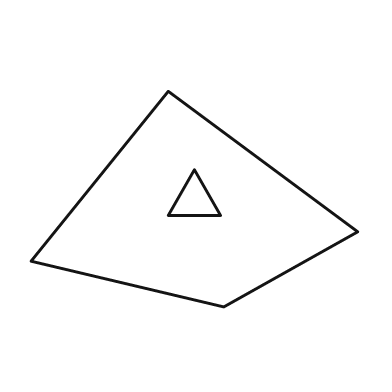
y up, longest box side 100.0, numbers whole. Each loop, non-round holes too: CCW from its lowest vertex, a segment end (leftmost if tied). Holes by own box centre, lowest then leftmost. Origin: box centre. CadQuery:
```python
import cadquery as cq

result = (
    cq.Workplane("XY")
    .moveTo(9.0, -33.0)
    .lineTo(50.0, -10.0)
    .lineTo(-8.0, 33.0)
    .lineTo(-50.0, -19.0)
    .close()
    .moveTo(-8.0, -5.0)
    .lineTo(8.0, -5.0)
    .lineTo(0.0, 9.0)
    .close()
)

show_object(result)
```